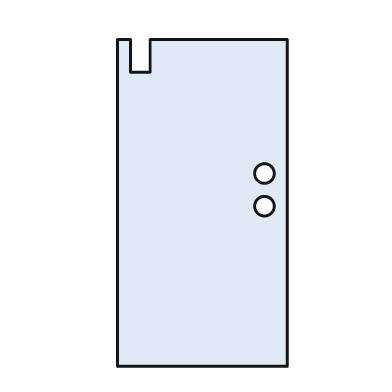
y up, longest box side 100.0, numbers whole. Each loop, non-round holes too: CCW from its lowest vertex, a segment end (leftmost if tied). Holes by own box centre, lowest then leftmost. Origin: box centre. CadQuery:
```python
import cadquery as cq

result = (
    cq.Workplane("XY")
    .moveTo(-26.0, -50.0)
    .lineTo(26.0, -50.0)
    .lineTo(26.0, 50.0)
    .lineTo(-16.0, 50.0)
    .lineTo(-16.0, 40.0)
    .lineTo(-22.0, 40.0)
    .lineTo(-22.0, 50.0)
    .lineTo(-26.0, 50.0)
    .close()
    .moveTo(19.0, -1.0)
    .circle(3.0)
    .moveTo(19.0, 9.0)
    .circle(3.0)
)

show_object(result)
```